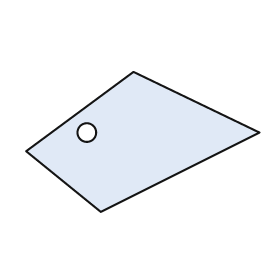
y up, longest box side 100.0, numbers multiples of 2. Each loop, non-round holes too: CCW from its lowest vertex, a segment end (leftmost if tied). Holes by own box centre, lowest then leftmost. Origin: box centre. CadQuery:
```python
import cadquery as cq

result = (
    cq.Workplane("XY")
    .moveTo(-18.0, -30.0)
    .lineTo(50.0, 4.0)
    .lineTo(-4.0, 30.0)
    .lineTo(-50.0, -4.0)
    .close()
    .moveTo(-24.0, 4.0)
    .circle(4.0)
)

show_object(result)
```